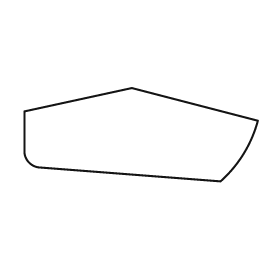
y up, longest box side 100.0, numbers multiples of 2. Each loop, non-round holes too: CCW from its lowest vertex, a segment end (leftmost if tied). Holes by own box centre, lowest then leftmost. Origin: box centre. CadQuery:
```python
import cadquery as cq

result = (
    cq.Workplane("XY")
    .moveTo(34.0, -20.0)
    .threePointArc((44.0, -8.0), (50.0, 6.0))
    .lineTo(-4.0, 20.0)
    .lineTo(-50.0, 10.0)
    .lineTo(-50.0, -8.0)
    .threePointArc((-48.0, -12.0), (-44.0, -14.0))
    .close()
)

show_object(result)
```